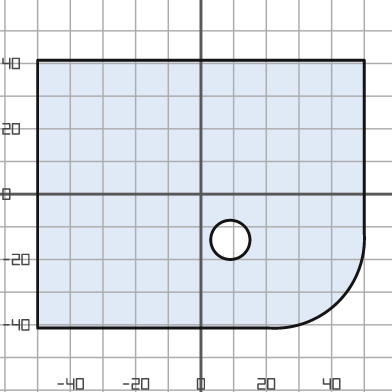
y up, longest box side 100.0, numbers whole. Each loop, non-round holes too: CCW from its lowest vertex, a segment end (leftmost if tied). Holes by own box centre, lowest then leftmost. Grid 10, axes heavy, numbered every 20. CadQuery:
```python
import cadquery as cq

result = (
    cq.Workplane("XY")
    .moveTo(-50.0, -41.0)
    .lineTo(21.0, -41.0)
    .threePointArc((42.0, -33.0), (50.0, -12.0))
    .lineTo(50.0, 41.0)
    .lineTo(-50.0, 41.0)
    .close()
    .moveTo(9.0, -14.0)
    .circle(6.0)
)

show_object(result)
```